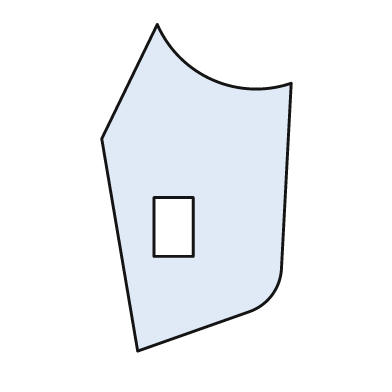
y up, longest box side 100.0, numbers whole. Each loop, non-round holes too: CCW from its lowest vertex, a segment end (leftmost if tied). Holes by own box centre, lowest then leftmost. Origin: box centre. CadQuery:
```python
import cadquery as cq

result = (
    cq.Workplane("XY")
    .moveTo(-18.0, -50.0)
    .lineTo(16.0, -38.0)
    .threePointArc((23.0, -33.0), (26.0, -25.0))
    .lineTo(29.0, 32.0)
    .threePointArc((5.0, 33.0), (-12.0, 50.0))
    .lineTo(-29.0, 15.0)
    .close()
    .moveTo(-13.0, -21.0)
    .lineTo(-1.0, -21.0)
    .lineTo(-1.0, -3.0)
    .lineTo(-13.0, -3.0)
    .close()
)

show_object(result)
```